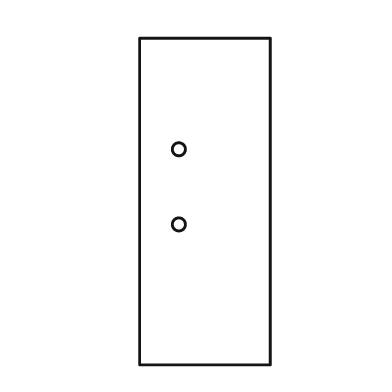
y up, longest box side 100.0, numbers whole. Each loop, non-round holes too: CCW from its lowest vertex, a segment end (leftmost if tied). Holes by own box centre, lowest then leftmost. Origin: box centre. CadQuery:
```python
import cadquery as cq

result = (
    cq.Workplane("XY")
    .moveTo(-20.0, -50.0)
    .lineTo(20.0, -50.0)
    .lineTo(20.0, 50.0)
    .lineTo(-20.0, 50.0)
    .close()
    .moveTo(-8.0, -7.0)
    .circle(2.0)
    .moveTo(-8.0, 16.0)
    .circle(2.0)
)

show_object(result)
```